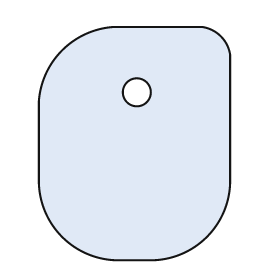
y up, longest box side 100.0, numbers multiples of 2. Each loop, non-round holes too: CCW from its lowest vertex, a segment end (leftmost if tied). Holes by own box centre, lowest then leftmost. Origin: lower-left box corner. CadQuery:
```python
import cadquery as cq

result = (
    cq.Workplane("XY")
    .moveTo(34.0, 0.0)
    .lineTo(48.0, 0.0)
    .threePointArc((72.0, 10.0), (82.0, 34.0))
    .lineTo(82.0, 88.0)
    .threePointArc((78.0, 96.0), (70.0, 100.0))
    .lineTo(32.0, 100.0)
    .threePointArc((10.0, 90.0), (0.0, 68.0))
    .lineTo(0.0, 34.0)
    .threePointArc((10.0, 10.0), (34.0, 0.0))
    .close()
    .moveTo(42.0, 72.0)
    .circle(6.0)
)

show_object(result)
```